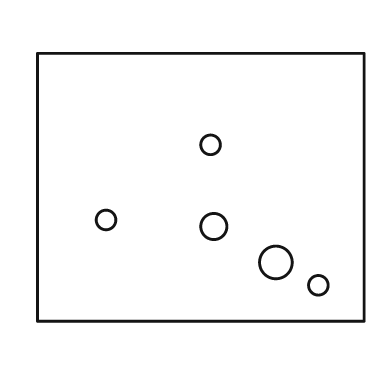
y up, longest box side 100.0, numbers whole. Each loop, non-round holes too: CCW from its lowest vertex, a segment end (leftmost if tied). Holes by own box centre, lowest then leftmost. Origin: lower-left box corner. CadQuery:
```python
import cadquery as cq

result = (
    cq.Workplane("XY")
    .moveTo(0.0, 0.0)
    .lineTo(100.0, 0.0)
    .lineTo(100.0, 82.0)
    .lineTo(0.0, 82.0)
    .close()
    .moveTo(86.0, 11.0)
    .circle(3.0)
    .moveTo(73.0, 18.0)
    .circle(5.0)
    .moveTo(54.0, 29.0)
    .circle(4.0)
    .moveTo(21.0, 31.0)
    .circle(3.0)
    .moveTo(53.0, 54.0)
    .circle(3.0)
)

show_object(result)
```